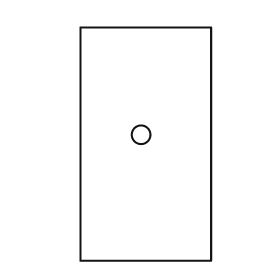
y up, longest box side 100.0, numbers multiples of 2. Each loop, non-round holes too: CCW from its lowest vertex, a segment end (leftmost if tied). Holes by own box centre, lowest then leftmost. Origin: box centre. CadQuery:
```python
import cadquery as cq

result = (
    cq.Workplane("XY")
    .moveTo(-28.0, -50.0)
    .lineTo(28.0, -50.0)
    .lineTo(28.0, 50.0)
    .lineTo(-28.0, 50.0)
    .close()
    .moveTo(-2.0, 4.0)
    .circle(4.0)
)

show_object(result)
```